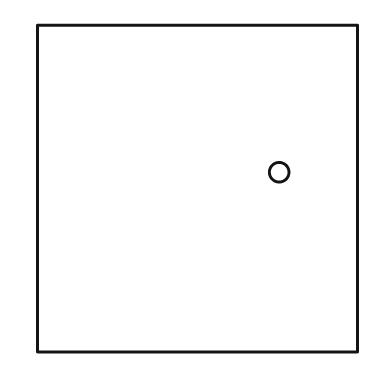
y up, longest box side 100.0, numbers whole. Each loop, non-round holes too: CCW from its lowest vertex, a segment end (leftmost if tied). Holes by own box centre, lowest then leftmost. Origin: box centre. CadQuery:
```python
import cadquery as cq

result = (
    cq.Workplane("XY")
    .moveTo(-49.0, -50.0)
    .lineTo(49.0, -50.0)
    .lineTo(49.0, 50.0)
    .lineTo(-49.0, 50.0)
    .close()
    .moveTo(25.0, 5.0)
    .circle(3.0)
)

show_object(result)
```